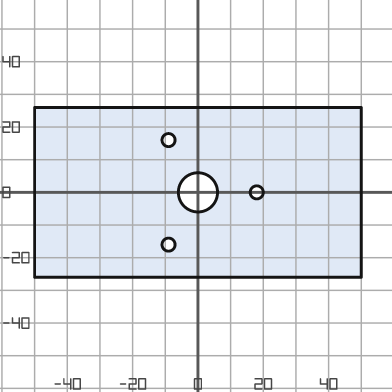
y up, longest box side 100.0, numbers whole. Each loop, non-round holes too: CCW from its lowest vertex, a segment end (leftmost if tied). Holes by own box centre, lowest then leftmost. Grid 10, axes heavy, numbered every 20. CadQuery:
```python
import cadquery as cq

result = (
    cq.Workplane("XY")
    .moveTo(-50.0, -26.0)
    .lineTo(50.0, -26.0)
    .lineTo(50.0, 26.0)
    .lineTo(-50.0, 26.0)
    .close()
    .moveTo(-9.0, -16.0)
    .circle(2.0)
    .moveTo(0.0, 0.0)
    .circle(6.0)
    .moveTo(18.0, 0.0)
    .circle(2.0)
    .moveTo(-9.0, 16.0)
    .circle(2.0)
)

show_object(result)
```